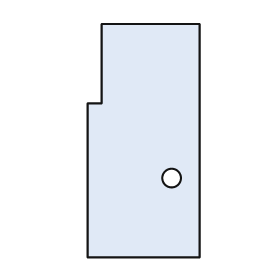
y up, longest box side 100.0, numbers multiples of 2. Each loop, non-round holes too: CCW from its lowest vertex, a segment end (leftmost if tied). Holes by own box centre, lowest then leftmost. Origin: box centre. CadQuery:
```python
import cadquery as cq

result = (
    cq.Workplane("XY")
    .moveTo(-24.0, -50.0)
    .lineTo(24.0, -50.0)
    .lineTo(24.0, 50.0)
    .lineTo(-18.0, 50.0)
    .lineTo(-18.0, 16.0)
    .lineTo(-24.0, 16.0)
    .close()
    .moveTo(12.0, -16.0)
    .circle(4.0)
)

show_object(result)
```